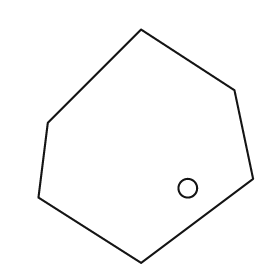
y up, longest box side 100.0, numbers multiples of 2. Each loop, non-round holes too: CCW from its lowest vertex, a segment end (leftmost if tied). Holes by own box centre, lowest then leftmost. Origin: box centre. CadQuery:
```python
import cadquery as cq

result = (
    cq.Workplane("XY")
    .moveTo(-2.0, -50.0)
    .lineTo(46.0, -14.0)
    .lineTo(38.0, 24.0)
    .lineTo(-2.0, 50.0)
    .lineTo(-42.0, 10.0)
    .lineTo(-46.0, -22.0)
    .close()
    .moveTo(18.0, -18.0)
    .circle(4.0)
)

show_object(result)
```